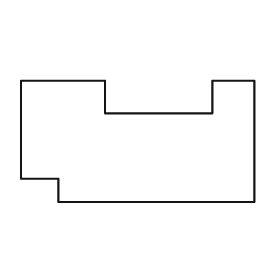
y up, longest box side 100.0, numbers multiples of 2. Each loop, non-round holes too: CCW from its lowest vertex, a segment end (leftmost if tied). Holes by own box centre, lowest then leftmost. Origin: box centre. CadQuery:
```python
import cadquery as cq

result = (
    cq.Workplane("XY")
    .moveTo(-34.0, -26.0)
    .lineTo(50.0, -26.0)
    .lineTo(50.0, 26.0)
    .lineTo(32.0, 26.0)
    .lineTo(32.0, 12.0)
    .lineTo(-14.0, 12.0)
    .lineTo(-14.0, 26.0)
    .lineTo(-50.0, 26.0)
    .lineTo(-50.0, -16.0)
    .lineTo(-34.0, -16.0)
    .close()
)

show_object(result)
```